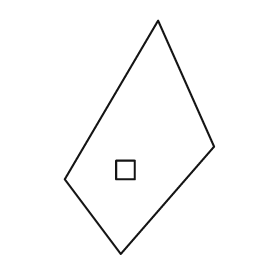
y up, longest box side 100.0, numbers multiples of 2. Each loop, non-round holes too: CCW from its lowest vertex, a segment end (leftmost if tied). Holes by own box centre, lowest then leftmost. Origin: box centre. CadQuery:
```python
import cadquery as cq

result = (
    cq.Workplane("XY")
    .moveTo(-8.0, -50.0)
    .lineTo(32.0, -4.0)
    .lineTo(8.0, 50.0)
    .lineTo(-32.0, -18.0)
    .close()
    .moveTo(-10.0, -18.0)
    .lineTo(-2.0, -18.0)
    .lineTo(-2.0, -10.0)
    .lineTo(-10.0, -10.0)
    .close()
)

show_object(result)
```